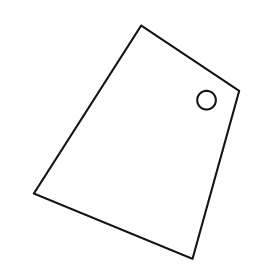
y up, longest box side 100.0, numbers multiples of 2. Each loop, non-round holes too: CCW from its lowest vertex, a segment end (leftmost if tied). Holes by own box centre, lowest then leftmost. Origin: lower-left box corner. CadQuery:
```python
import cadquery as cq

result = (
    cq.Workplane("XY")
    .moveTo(68.0, 0.0)
    .lineTo(88.0, 72.0)
    .lineTo(46.0, 100.0)
    .lineTo(0.0, 28.0)
    .close()
    .moveTo(74.0, 68.0)
    .circle(4.0)
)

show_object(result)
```